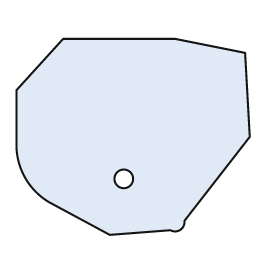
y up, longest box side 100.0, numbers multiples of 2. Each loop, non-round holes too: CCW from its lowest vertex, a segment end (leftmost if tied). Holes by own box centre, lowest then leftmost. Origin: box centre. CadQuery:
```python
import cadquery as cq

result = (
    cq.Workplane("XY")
    .moveTo(-10.0, -42.0)
    .lineTo(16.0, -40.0)
    .threePointArc((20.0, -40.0), (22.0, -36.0))
    .lineTo(50.0, 0.0)
    .lineTo(48.0, 36.0)
    .lineTo(18.0, 42.0)
    .lineTo(-30.0, 42.0)
    .lineTo(-50.0, 20.0)
    .lineTo(-50.0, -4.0)
    .threePointArc((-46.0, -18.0), (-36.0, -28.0))
    .close()
    .moveTo(-4.0, -18.0)
    .circle(4.0)
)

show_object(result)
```